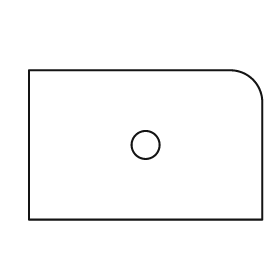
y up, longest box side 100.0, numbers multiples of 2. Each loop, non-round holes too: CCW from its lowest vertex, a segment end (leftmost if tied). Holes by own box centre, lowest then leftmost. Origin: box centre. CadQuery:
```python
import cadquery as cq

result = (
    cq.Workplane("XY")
    .moveTo(-50.0, -32.0)
    .lineTo(50.0, -32.0)
    .lineTo(50.0, 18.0)
    .threePointArc((46.0, 28.0), (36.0, 32.0))
    .lineTo(-50.0, 32.0)
    .close()
    .moveTo(0.0, 0.0)
    .circle(6.0)
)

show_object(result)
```